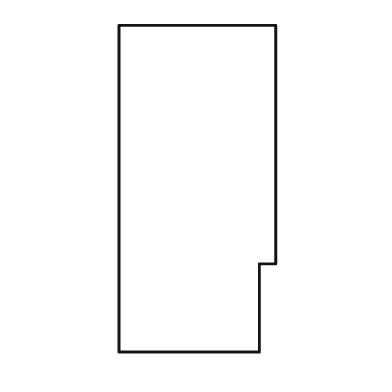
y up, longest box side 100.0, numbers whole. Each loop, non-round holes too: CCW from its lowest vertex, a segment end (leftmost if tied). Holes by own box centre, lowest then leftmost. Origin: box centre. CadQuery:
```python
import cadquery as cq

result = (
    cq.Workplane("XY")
    .moveTo(-24.0, -50.0)
    .lineTo(19.0, -50.0)
    .lineTo(19.0, -23.0)
    .lineTo(24.0, -23.0)
    .lineTo(24.0, 50.0)
    .lineTo(-24.0, 50.0)
    .close()
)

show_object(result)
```